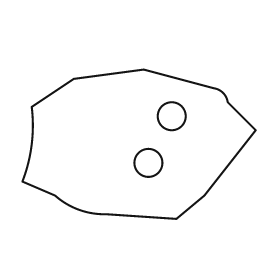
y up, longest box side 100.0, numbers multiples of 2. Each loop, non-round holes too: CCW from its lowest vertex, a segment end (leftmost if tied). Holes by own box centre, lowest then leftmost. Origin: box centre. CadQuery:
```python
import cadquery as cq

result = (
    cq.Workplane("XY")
    .moveTo(16.0, -32.0)
    .lineTo(28.0, -22.0)
    .lineTo(50.0, 6.0)
    .lineTo(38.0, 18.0)
    .threePointArc((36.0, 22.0), (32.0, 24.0))
    .lineTo(2.0, 32.0)
    .lineTo(-28.0, 28.0)
    .lineTo(-46.0, 16.0)
    .threePointArc((-46.0, 0.0), (-50.0, -16.0))
    .lineTo(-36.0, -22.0)
    .threePointArc((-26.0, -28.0), (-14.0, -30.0))
    .close()
    .moveTo(4.0, -8.0)
    .circle(6.0)
    .moveTo(14.0, 12.0)
    .circle(6.0)
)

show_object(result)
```